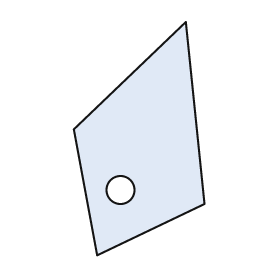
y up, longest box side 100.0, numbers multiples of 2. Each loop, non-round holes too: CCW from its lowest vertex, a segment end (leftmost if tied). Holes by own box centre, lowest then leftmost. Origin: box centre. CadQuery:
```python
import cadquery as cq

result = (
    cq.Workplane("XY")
    .moveTo(-18.0, -50.0)
    .lineTo(28.0, -28.0)
    .lineTo(20.0, 50.0)
    .lineTo(-28.0, 4.0)
    .close()
    .moveTo(-8.0, -22.0)
    .circle(6.0)
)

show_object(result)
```